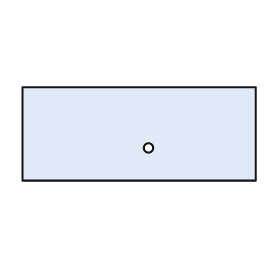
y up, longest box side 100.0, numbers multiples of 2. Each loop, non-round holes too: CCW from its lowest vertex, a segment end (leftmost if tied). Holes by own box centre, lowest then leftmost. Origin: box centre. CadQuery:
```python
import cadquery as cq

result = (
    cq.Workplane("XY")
    .moveTo(-50.0, -20.0)
    .lineTo(50.0, -20.0)
    .lineTo(50.0, 20.0)
    .lineTo(-50.0, 20.0)
    .close()
    .moveTo(4.0, -6.0)
    .circle(2.0)
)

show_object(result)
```